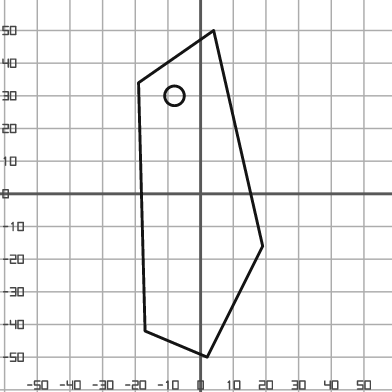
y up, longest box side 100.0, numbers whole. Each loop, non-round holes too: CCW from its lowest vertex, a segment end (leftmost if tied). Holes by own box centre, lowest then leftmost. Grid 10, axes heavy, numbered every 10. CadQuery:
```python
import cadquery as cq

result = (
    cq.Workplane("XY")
    .moveTo(2.0, -50.0)
    .lineTo(19.0, -16.0)
    .lineTo(4.0, 50.0)
    .lineTo(-19.0, 34.0)
    .lineTo(-17.0, -42.0)
    .close()
    .moveTo(-8.0, 30.0)
    .circle(3.0)
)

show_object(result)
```